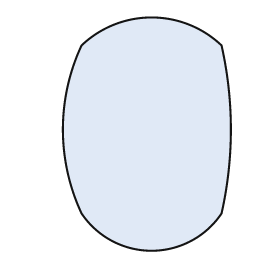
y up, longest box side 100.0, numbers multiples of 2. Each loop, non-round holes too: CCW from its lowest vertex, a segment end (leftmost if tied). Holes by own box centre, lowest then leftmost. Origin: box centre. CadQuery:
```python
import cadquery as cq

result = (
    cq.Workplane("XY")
    .moveTo(-28.0, -34.0)
    .threePointArc((2.0, -50.0), (32.0, -34.0))
    .threePointArc((36.0, 2.0), (32.0, 38.0))
    .threePointArc((2.0, 50.0), (-28.0, 38.0))
    .threePointArc((-36.0, 2.0), (-28.0, -34.0))
    .close()
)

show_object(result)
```